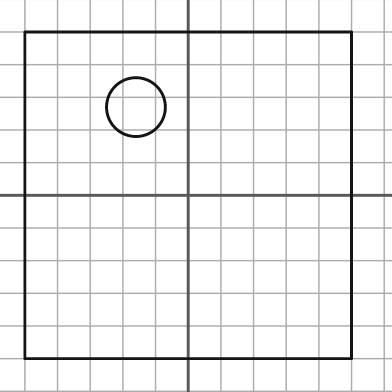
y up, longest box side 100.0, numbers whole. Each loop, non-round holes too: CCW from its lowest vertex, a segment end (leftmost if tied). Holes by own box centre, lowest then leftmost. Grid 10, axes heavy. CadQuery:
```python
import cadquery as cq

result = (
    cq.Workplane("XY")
    .moveTo(-50.0, -50.0)
    .lineTo(50.0, -50.0)
    .lineTo(50.0, 50.0)
    .lineTo(-50.0, 50.0)
    .close()
    .moveTo(-16.0, 27.0)
    .circle(9.0)
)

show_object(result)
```